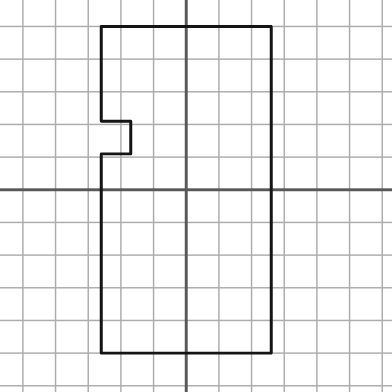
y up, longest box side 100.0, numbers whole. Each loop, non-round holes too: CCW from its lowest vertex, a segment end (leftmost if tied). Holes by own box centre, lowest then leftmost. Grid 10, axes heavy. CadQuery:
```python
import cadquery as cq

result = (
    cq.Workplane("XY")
    .moveTo(-26.0, -50.0)
    .lineTo(26.0, -50.0)
    .lineTo(26.0, 50.0)
    .lineTo(-26.0, 50.0)
    .lineTo(-26.0, 21.0)
    .lineTo(-17.0, 21.0)
    .lineTo(-17.0, 11.0)
    .lineTo(-26.0, 11.0)
    .close()
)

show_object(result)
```